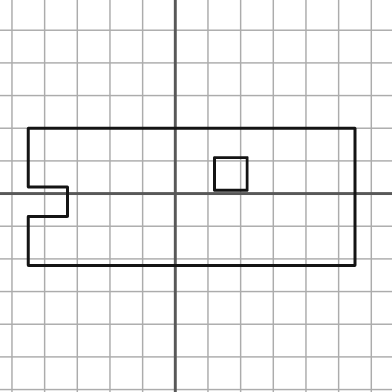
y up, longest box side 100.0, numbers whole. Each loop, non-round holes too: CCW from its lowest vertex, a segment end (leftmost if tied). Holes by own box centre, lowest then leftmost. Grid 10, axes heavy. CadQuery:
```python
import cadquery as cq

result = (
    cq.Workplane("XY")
    .moveTo(-45.0, -22.0)
    .lineTo(55.0, -22.0)
    .lineTo(55.0, 20.0)
    .lineTo(-45.0, 20.0)
    .lineTo(-45.0, 2.0)
    .lineTo(-33.0, 2.0)
    .lineTo(-33.0, -7.0)
    .lineTo(-45.0, -7.0)
    .close()
    .moveTo(12.0, 1.0)
    .lineTo(22.0, 1.0)
    .lineTo(22.0, 11.0)
    .lineTo(12.0, 11.0)
    .close()
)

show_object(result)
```